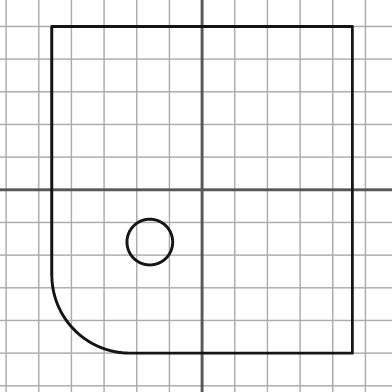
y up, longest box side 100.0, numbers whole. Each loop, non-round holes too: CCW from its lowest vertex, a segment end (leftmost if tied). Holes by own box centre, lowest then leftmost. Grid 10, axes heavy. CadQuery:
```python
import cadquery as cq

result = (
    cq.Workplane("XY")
    .moveTo(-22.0, -50.0)
    .lineTo(46.0, -50.0)
    .lineTo(46.0, 50.0)
    .lineTo(-46.0, 50.0)
    .lineTo(-46.0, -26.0)
    .threePointArc((-39.0, -43.0), (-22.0, -50.0))
    .close()
    .moveTo(-16.0, -16.0)
    .circle(7.0)
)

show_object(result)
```